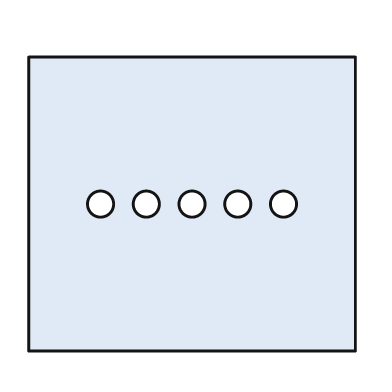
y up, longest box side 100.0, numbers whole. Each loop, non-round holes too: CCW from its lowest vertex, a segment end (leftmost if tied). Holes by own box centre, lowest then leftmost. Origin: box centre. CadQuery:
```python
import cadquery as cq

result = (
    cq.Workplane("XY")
    .moveTo(-50.0, -45.0)
    .lineTo(50.0, -45.0)
    .lineTo(50.0, 45.0)
    .lineTo(-50.0, 45.0)
    .close()
    .moveTo(-28.0, 0.0)
    .circle(4.0)
    .moveTo(-14.0, 0.0)
    .circle(4.0)
    .moveTo(0.0, 0.0)
    .circle(4.0)
    .moveTo(14.0, 0.0)
    .circle(4.0)
    .moveTo(28.0, 0.0)
    .circle(4.0)
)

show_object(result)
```